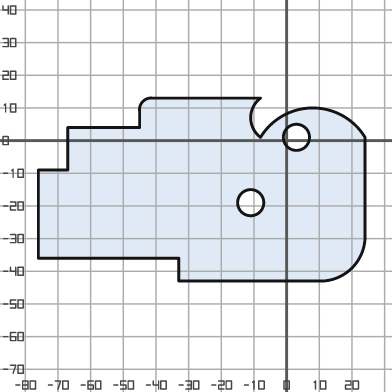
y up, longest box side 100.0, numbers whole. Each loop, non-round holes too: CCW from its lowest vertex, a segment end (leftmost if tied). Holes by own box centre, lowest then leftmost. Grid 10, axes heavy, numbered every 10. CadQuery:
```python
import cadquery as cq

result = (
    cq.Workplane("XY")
    .moveTo(-33.0, -43.0)
    .lineTo(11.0, -43.0)
    .threePointArc((20.0, -39.0), (24.0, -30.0))
    .lineTo(24.0, 1.0)
    .threePointArc((8.0, 10.0), (-8.0, 1.0))
    .threePointArc((-11.0, 7.0), (-8.0, 13.0))
    .lineTo(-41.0, 13.0)
    .threePointArc((-44.0, 12.0), (-45.0, 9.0))
    .lineTo(-45.0, 4.0)
    .lineTo(-67.0, 4.0)
    .lineTo(-67.0, -9.0)
    .lineTo(-76.0, -9.0)
    .lineTo(-76.0, -36.0)
    .lineTo(-33.0, -36.0)
    .close()
    .moveTo(-11.0, -19.0)
    .circle(4.0)
    .moveTo(3.0, 1.0)
    .circle(4.0)
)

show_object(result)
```